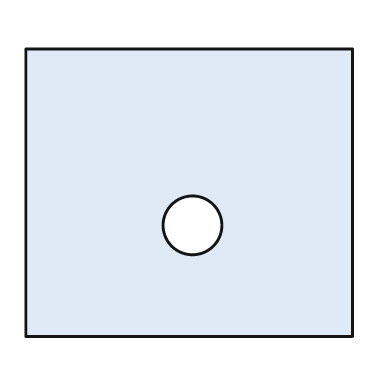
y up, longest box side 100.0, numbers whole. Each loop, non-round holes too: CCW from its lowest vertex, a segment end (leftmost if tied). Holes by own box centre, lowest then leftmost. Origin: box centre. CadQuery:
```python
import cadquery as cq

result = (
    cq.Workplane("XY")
    .moveTo(-50.0, -44.0)
    .lineTo(50.0, -44.0)
    .lineTo(50.0, 44.0)
    .lineTo(-50.0, 44.0)
    .close()
    .moveTo(1.0, -10.0)
    .circle(9.0)
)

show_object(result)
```